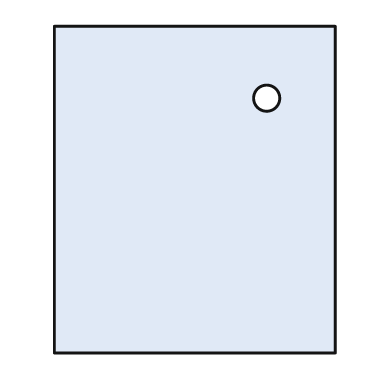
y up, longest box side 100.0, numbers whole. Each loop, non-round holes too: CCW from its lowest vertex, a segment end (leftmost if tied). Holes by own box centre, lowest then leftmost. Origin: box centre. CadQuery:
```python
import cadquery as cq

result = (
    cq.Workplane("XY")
    .moveTo(-43.0, -50.0)
    .lineTo(43.0, -50.0)
    .lineTo(43.0, 50.0)
    .lineTo(-43.0, 50.0)
    .close()
    .moveTo(22.0, 28.0)
    .circle(4.0)
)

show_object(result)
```